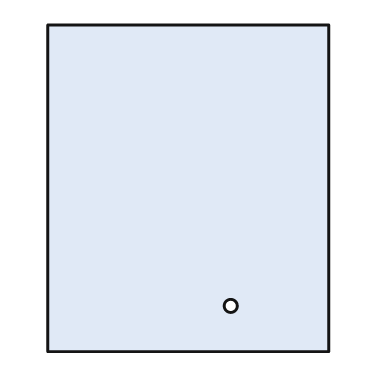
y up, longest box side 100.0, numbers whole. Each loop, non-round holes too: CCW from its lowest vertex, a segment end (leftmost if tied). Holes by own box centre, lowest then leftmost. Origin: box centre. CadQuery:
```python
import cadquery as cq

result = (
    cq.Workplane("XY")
    .moveTo(-43.0, -50.0)
    .lineTo(43.0, -50.0)
    .lineTo(43.0, 50.0)
    .lineTo(-43.0, 50.0)
    .close()
    .moveTo(13.0, -36.0)
    .circle(2.0)
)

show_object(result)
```